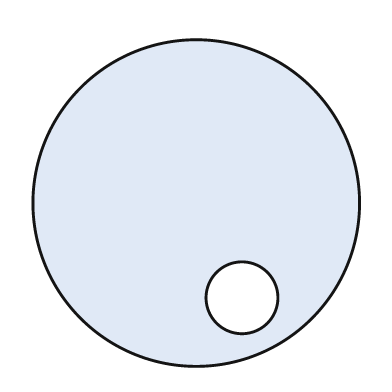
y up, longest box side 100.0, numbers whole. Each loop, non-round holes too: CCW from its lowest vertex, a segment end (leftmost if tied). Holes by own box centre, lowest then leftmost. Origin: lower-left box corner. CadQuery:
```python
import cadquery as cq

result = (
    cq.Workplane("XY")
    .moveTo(50.0, 50.0)
    .circle(50.0)
    .moveTo(64.0, 21.0)
    .circle(11.0)
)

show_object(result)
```